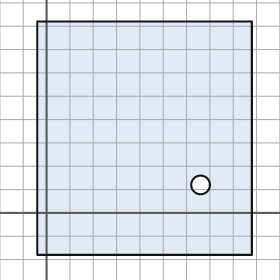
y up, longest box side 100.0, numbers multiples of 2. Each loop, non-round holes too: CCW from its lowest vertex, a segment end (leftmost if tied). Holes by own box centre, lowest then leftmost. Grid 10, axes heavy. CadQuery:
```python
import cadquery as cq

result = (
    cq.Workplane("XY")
    .moveTo(-4.0, -18.0)
    .lineTo(88.0, -18.0)
    .lineTo(88.0, 82.0)
    .lineTo(-4.0, 82.0)
    .close()
    .moveTo(66.0, 12.0)
    .circle(4.0)
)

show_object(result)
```